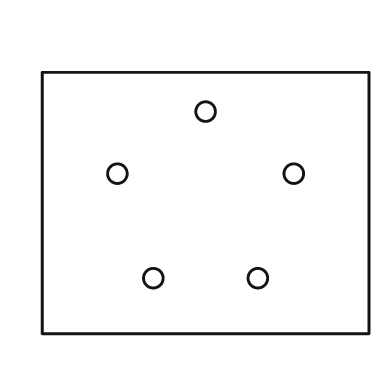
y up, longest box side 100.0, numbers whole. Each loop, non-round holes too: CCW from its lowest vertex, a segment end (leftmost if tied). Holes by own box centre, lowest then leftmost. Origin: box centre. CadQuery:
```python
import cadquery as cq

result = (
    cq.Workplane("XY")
    .moveTo(-50.0, -40.0)
    .lineTo(50.0, -40.0)
    .lineTo(50.0, 40.0)
    .lineTo(-50.0, 40.0)
    .close()
    .moveTo(-16.0, -23.0)
    .circle(3.0)
    .moveTo(16.0, -23.0)
    .circle(3.0)
    .moveTo(-27.0, 9.0)
    .circle(3.0)
    .moveTo(27.0, 9.0)
    .circle(3.0)
    .moveTo(0.0, 28.0)
    .circle(3.0)
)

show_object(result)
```